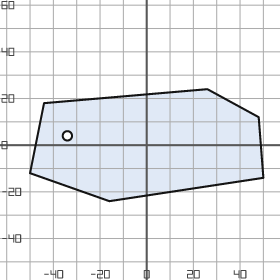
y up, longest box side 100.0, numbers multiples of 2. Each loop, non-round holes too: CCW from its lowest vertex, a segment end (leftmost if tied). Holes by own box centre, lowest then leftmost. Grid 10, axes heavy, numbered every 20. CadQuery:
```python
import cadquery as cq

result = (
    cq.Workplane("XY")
    .moveTo(-16.0, -24.0)
    .lineTo(50.0, -14.0)
    .lineTo(48.0, 12.0)
    .lineTo(26.0, 24.0)
    .lineTo(-44.0, 18.0)
    .lineTo(-50.0, -12.0)
    .close()
    .moveTo(-34.0, 4.0)
    .circle(2.0)
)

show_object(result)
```